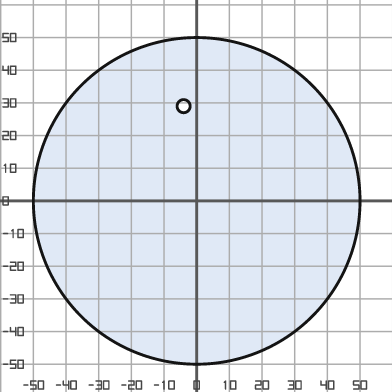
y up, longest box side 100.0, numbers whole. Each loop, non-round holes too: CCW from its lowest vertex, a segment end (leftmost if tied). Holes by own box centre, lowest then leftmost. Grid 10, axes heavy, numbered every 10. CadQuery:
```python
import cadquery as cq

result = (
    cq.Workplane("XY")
    .moveTo(0.0, 0.0)
    .circle(50.0)
    .moveTo(-4.0, 29.0)
    .circle(2.0)
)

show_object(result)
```